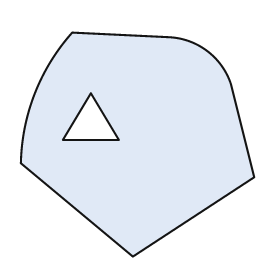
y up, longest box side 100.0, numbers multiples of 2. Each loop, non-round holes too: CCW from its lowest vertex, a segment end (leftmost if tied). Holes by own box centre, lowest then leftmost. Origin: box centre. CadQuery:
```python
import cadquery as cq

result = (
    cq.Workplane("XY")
    .moveTo(-2.0, -48.0)
    .lineTo(50.0, -14.0)
    .lineTo(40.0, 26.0)
    .threePointArc((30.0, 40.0), (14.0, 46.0))
    .lineTo(-28.0, 48.0)
    .threePointArc((-44.0, 22.0), (-50.0, -8.0))
    .close()
    .moveTo(-32.0, 2.0)
    .lineTo(-8.0, 2.0)
    .lineTo(-20.0, 22.0)
    .close()
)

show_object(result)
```